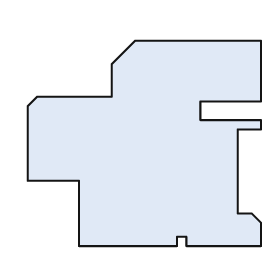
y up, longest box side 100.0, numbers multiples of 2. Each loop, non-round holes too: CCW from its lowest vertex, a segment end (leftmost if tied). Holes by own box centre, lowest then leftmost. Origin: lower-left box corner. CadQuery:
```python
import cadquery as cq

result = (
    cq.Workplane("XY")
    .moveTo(22.0, 0.0)
    .lineTo(64.0, 0.0)
    .lineTo(64.0, 4.0)
    .lineTo(68.0, 4.0)
    .lineTo(68.0, 0.0)
    .lineTo(100.0, 0.0)
    .lineTo(100.0, 10.0)
    .lineTo(96.0, 14.0)
    .lineTo(90.0, 14.0)
    .lineTo(90.0, 50.0)
    .lineTo(100.0, 50.0)
    .lineTo(100.0, 54.0)
    .lineTo(74.0, 54.0)
    .lineTo(74.0, 62.0)
    .lineTo(100.0, 62.0)
    .lineTo(100.0, 88.0)
    .lineTo(46.0, 88.0)
    .lineTo(36.0, 78.0)
    .lineTo(36.0, 64.0)
    .lineTo(4.0, 64.0)
    .lineTo(0.0, 60.0)
    .lineTo(0.0, 28.0)
    .lineTo(22.0, 28.0)
    .close()
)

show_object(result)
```